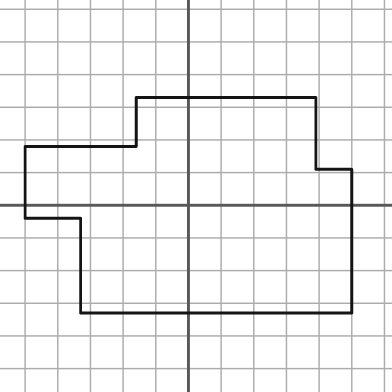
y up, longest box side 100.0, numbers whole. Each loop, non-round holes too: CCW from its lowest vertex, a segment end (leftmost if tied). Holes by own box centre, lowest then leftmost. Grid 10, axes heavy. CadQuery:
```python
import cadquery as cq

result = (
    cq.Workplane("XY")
    .moveTo(-33.0, -33.0)
    .lineTo(50.0, -33.0)
    .lineTo(50.0, 11.0)
    .lineTo(39.0, 11.0)
    .lineTo(39.0, 33.0)
    .lineTo(-16.0, 33.0)
    .lineTo(-16.0, 18.0)
    .lineTo(-50.0, 18.0)
    .lineTo(-50.0, -4.0)
    .lineTo(-33.0, -4.0)
    .close()
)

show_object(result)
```